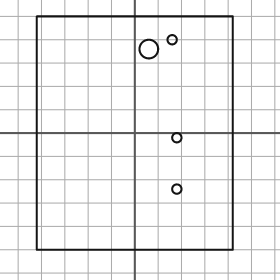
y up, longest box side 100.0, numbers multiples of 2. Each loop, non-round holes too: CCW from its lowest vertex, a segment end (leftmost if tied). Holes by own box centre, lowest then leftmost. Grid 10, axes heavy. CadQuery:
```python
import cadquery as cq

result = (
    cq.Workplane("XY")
    .moveTo(-42.0, -50.0)
    .lineTo(42.0, -50.0)
    .lineTo(42.0, 50.0)
    .lineTo(-42.0, 50.0)
    .close()
    .moveTo(18.0, -24.0)
    .circle(2.0)
    .moveTo(18.0, -2.0)
    .circle(2.0)
    .moveTo(6.0, 36.0)
    .circle(4.0)
    .moveTo(16.0, 40.0)
    .circle(2.0)
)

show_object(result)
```